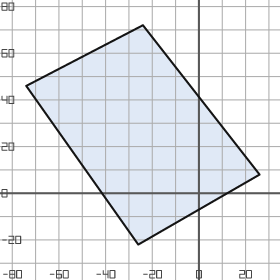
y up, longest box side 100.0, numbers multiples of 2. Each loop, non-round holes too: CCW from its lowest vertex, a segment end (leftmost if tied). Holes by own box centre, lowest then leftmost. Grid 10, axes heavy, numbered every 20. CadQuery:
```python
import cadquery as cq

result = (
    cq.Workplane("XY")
    .moveTo(-26.0, -22.0)
    .lineTo(26.0, 8.0)
    .lineTo(-24.0, 72.0)
    .lineTo(-74.0, 46.0)
    .close()
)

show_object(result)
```